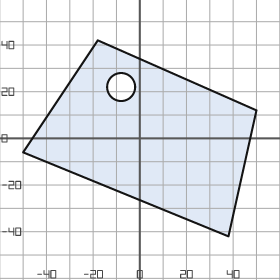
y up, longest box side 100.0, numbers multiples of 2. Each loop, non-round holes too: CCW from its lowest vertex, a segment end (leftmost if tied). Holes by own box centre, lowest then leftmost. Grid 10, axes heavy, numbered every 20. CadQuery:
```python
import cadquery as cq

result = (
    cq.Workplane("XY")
    .moveTo(38.0, -42.0)
    .lineTo(50.0, 12.0)
    .lineTo(-18.0, 42.0)
    .lineTo(-50.0, -6.0)
    .close()
    .moveTo(-8.0, 22.0)
    .circle(6.0)
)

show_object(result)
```